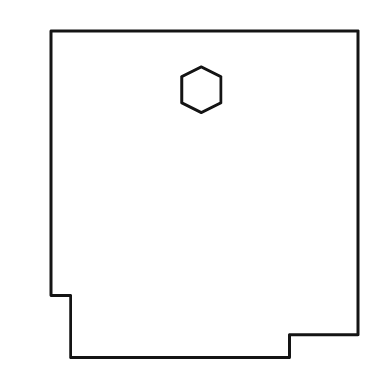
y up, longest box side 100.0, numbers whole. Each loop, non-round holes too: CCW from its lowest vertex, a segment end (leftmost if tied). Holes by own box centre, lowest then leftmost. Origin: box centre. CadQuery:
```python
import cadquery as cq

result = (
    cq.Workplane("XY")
    .moveTo(-41.0, -50.0)
    .lineTo(26.0, -50.0)
    .lineTo(26.0, -43.0)
    .lineTo(47.0, -43.0)
    .lineTo(47.0, 50.0)
    .lineTo(-47.0, 50.0)
    .lineTo(-47.0, -31.0)
    .lineTo(-41.0, -31.0)
    .close()
    .moveTo(-1.0, 25.0)
    .lineTo(5.0, 28.0)
    .lineTo(5.0, 36.0)
    .lineTo(-1.0, 39.0)
    .lineTo(-7.0, 36.0)
    .lineTo(-7.0, 28.0)
    .close()
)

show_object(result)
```